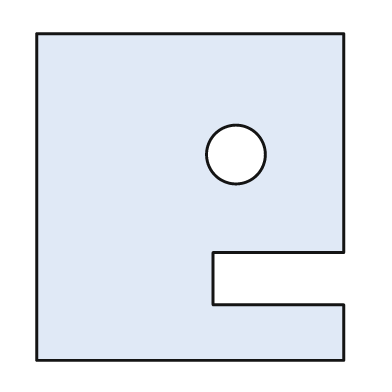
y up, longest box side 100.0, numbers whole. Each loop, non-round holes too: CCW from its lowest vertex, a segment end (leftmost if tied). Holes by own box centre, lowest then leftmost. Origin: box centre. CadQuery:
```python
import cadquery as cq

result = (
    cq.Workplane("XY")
    .moveTo(-47.0, -50.0)
    .lineTo(47.0, -50.0)
    .lineTo(47.0, -33.0)
    .lineTo(7.0, -33.0)
    .lineTo(7.0, -17.0)
    .lineTo(47.0, -17.0)
    .lineTo(47.0, 50.0)
    .lineTo(-47.0, 50.0)
    .close()
    .moveTo(14.0, 13.0)
    .circle(9.0)
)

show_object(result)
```